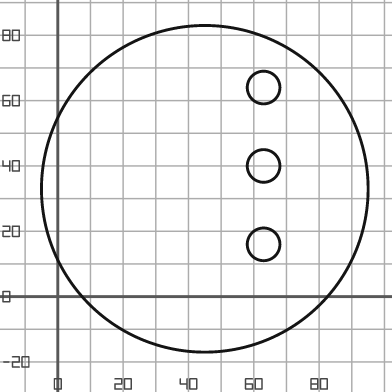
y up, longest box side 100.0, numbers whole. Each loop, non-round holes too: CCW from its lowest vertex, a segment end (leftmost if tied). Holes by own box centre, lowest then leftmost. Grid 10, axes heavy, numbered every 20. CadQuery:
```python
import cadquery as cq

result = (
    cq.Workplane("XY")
    .moveTo(45.0, 33.0)
    .circle(50.0)
    .moveTo(63.0, 16.0)
    .circle(5.0)
    .moveTo(63.0, 40.0)
    .circle(5.0)
    .moveTo(63.0, 64.0)
    .circle(5.0)
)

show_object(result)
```